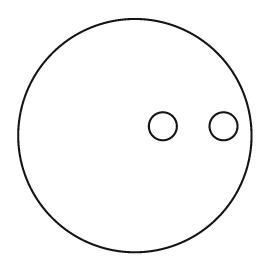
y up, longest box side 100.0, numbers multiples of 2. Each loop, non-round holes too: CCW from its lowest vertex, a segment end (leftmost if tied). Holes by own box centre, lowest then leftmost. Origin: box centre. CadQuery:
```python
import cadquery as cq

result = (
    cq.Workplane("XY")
    .moveTo(0.0, 0.0)
    .circle(50.0)
    .moveTo(12.0, 4.0)
    .circle(6.0)
    .moveTo(38.0, 4.0)
    .circle(6.0)
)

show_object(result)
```